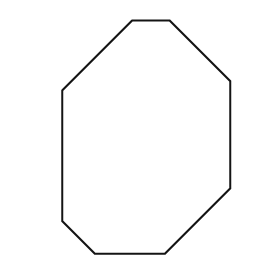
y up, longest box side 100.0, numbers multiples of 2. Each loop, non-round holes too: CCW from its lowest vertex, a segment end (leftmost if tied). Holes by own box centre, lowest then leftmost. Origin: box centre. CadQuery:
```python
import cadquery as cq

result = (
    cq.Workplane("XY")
    .moveTo(-22.0, -50.0)
    .lineTo(8.0, -50.0)
    .lineTo(36.0, -22.0)
    .lineTo(36.0, 24.0)
    .lineTo(10.0, 50.0)
    .lineTo(-6.0, 50.0)
    .lineTo(-36.0, 20.0)
    .lineTo(-36.0, -36.0)
    .close()
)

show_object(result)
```